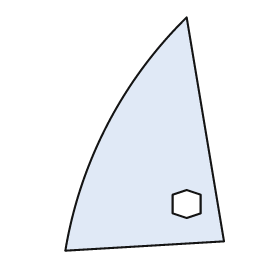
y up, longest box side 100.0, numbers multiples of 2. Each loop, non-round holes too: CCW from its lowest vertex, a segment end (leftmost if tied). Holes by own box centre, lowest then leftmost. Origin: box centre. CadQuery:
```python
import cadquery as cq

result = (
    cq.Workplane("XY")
    .moveTo(-34.0, -50.0)
    .lineTo(34.0, -46.0)
    .lineTo(18.0, 50.0)
    .threePointArc((-16.0, 4.0), (-34.0, -50.0))
    .close()
    .moveTo(18.0, -36.0)
    .lineTo(24.0, -34.0)
    .lineTo(24.0, -26.0)
    .lineTo(18.0, -24.0)
    .lineTo(12.0, -26.0)
    .lineTo(12.0, -34.0)
    .close()
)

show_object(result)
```